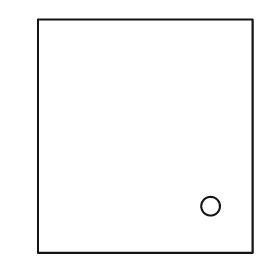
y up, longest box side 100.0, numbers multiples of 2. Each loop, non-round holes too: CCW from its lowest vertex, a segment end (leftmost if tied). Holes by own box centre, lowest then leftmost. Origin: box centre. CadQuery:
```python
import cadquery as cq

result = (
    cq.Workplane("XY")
    .moveTo(-46.0, -50.0)
    .lineTo(46.0, -50.0)
    .lineTo(46.0, 50.0)
    .lineTo(-46.0, 50.0)
    .close()
    .moveTo(28.0, -30.0)
    .circle(4.0)
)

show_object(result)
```